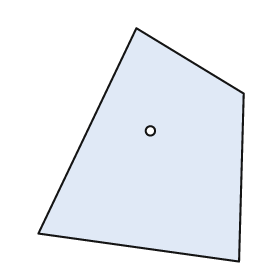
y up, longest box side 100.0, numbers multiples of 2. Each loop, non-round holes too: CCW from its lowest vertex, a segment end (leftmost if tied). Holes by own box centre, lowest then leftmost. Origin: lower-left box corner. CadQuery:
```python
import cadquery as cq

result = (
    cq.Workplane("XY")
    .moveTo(86.0, 0.0)
    .lineTo(88.0, 72.0)
    .lineTo(42.0, 100.0)
    .lineTo(0.0, 12.0)
    .close()
    .moveTo(48.0, 56.0)
    .circle(2.0)
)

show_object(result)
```